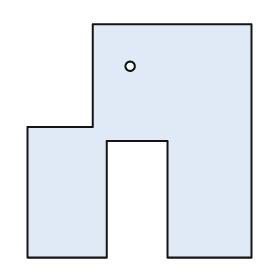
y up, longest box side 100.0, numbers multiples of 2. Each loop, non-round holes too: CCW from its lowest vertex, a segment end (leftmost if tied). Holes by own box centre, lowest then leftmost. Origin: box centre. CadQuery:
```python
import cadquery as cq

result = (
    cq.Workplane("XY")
    .moveTo(-48.0, -50.0)
    .lineTo(-14.0, -50.0)
    .lineTo(-14.0, 0.0)
    .lineTo(12.0, 0.0)
    .lineTo(12.0, -50.0)
    .lineTo(48.0, -50.0)
    .lineTo(48.0, 50.0)
    .lineTo(-20.0, 50.0)
    .lineTo(-20.0, 6.0)
    .lineTo(-48.0, 6.0)
    .close()
    .moveTo(-4.0, 32.0)
    .circle(2.0)
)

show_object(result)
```